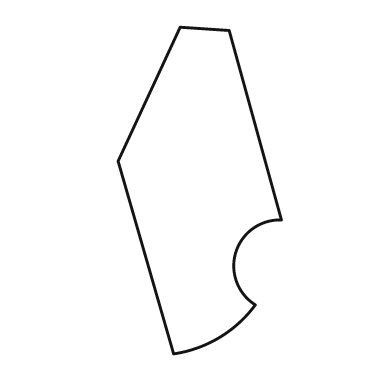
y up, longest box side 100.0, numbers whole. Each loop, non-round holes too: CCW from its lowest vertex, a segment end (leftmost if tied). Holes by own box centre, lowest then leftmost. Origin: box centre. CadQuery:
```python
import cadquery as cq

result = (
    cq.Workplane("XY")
    .moveTo(-8.0, -50.0)
    .threePointArc((6.0, -45.0), (17.0, -35.0))
    .threePointArc((11.0, -19.0), (25.0, -9.0))
    .lineTo(9.0, 49.0)
    .lineTo(-6.0, 50.0)
    .lineTo(-25.0, 9.0)
    .close()
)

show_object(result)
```